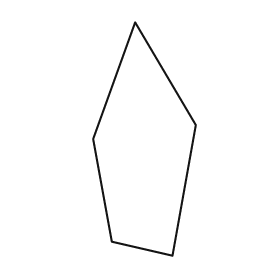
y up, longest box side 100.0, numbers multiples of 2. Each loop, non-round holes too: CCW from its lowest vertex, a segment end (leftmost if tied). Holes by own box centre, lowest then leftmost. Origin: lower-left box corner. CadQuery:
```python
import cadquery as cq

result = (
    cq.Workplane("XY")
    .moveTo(34.0, 0.0)
    .lineTo(44.0, 56.0)
    .lineTo(18.0, 100.0)
    .lineTo(0.0, 50.0)
    .lineTo(8.0, 6.0)
    .close()
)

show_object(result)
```